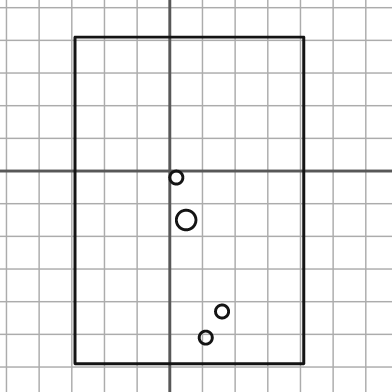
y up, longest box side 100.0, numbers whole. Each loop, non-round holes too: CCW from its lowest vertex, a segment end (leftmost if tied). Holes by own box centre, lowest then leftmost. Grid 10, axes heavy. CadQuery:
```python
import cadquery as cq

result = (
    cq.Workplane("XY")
    .moveTo(-29.0, -59.0)
    .lineTo(41.0, -59.0)
    .lineTo(41.0, 41.0)
    .lineTo(-29.0, 41.0)
    .close()
    .moveTo(11.0, -51.0)
    .circle(2.0)
    .moveTo(16.0, -43.0)
    .circle(2.0)
    .moveTo(5.0, -15.0)
    .circle(3.0)
    .moveTo(2.0, -2.0)
    .circle(2.0)
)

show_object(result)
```